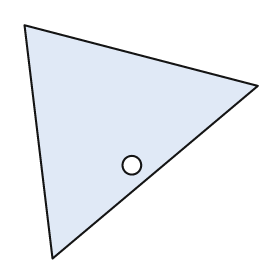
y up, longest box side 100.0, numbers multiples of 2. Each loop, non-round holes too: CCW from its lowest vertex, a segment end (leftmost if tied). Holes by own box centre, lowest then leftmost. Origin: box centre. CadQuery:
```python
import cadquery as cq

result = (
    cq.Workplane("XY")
    .moveTo(-38.0, -50.0)
    .lineTo(50.0, 24.0)
    .lineTo(-50.0, 50.0)
    .close()
    .moveTo(-4.0, -10.0)
    .circle(4.0)
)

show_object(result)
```